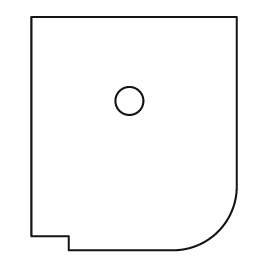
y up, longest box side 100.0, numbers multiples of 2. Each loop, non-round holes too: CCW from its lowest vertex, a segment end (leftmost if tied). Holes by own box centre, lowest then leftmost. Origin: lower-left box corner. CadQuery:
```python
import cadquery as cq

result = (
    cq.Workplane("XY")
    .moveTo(16.0, 0.0)
    .lineTo(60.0, 0.0)
    .threePointArc((80.0, 8.0), (88.0, 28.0))
    .lineTo(88.0, 100.0)
    .lineTo(0.0, 100.0)
    .lineTo(0.0, 6.0)
    .lineTo(16.0, 6.0)
    .close()
    .moveTo(42.0, 64.0)
    .circle(6.0)
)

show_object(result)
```